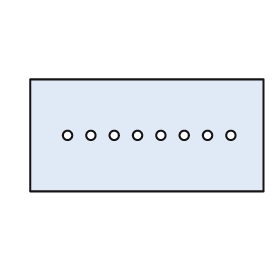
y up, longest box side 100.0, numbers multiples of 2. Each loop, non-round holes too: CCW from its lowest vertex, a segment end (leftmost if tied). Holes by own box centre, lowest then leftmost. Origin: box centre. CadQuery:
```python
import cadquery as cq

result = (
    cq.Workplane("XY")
    .moveTo(-50.0, -24.0)
    .lineTo(50.0, -24.0)
    .lineTo(50.0, 24.0)
    .lineTo(-50.0, 24.0)
    .close()
    .moveTo(-34.0, 0.0)
    .circle(2.0)
    .moveTo(-24.0, 0.0)
    .circle(2.0)
    .moveTo(-14.0, 0.0)
    .circle(2.0)
    .moveTo(-4.0, 0.0)
    .circle(2.0)
    .moveTo(6.0, 0.0)
    .circle(2.0)
    .moveTo(16.0, 0.0)
    .circle(2.0)
    .moveTo(26.0, 0.0)
    .circle(2.0)
    .moveTo(36.0, 0.0)
    .circle(2.0)
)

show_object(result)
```